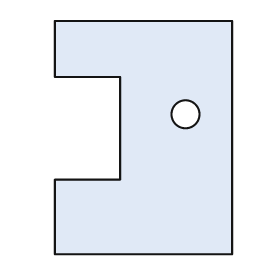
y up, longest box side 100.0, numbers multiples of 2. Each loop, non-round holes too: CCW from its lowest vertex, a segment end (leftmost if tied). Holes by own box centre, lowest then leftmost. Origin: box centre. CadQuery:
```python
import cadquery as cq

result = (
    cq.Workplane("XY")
    .moveTo(-38.0, -50.0)
    .lineTo(38.0, -50.0)
    .lineTo(38.0, 50.0)
    .lineTo(-38.0, 50.0)
    .lineTo(-38.0, 26.0)
    .lineTo(-10.0, 26.0)
    .lineTo(-10.0, -18.0)
    .lineTo(-38.0, -18.0)
    .close()
    .moveTo(18.0, 10.0)
    .circle(6.0)
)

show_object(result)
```